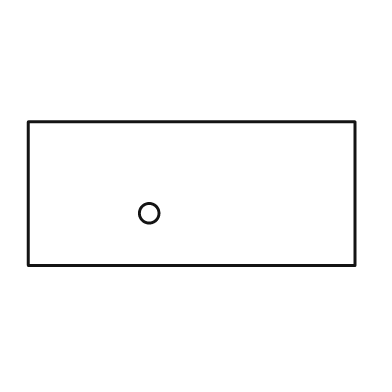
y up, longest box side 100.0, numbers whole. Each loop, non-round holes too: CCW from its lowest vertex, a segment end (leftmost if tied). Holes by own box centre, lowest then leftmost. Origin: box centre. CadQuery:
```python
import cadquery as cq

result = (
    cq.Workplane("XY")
    .moveTo(-50.0, -22.0)
    .lineTo(50.0, -22.0)
    .lineTo(50.0, 22.0)
    .lineTo(-50.0, 22.0)
    .close()
    .moveTo(-13.0, -6.0)
    .circle(3.0)
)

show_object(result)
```